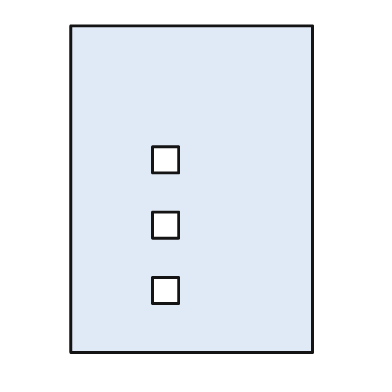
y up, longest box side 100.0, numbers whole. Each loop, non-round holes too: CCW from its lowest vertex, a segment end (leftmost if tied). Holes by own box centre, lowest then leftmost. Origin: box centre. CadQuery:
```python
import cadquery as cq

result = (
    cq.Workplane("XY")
    .moveTo(-37.0, -50.0)
    .lineTo(37.0, -50.0)
    .lineTo(37.0, 50.0)
    .lineTo(-37.0, 50.0)
    .close()
    .moveTo(-12.0, -35.0)
    .lineTo(-4.0, -35.0)
    .lineTo(-4.0, -27.0)
    .lineTo(-12.0, -27.0)
    .close()
    .moveTo(-12.0, -15.0)
    .lineTo(-4.0, -15.0)
    .lineTo(-4.0, -7.0)
    .lineTo(-12.0, -7.0)
    .close()
    .moveTo(-12.0, 5.0)
    .lineTo(-4.0, 5.0)
    .lineTo(-4.0, 13.0)
    .lineTo(-12.0, 13.0)
    .close()
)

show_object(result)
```